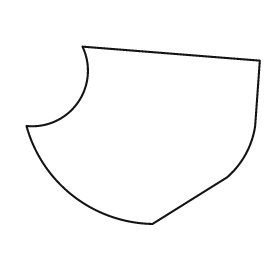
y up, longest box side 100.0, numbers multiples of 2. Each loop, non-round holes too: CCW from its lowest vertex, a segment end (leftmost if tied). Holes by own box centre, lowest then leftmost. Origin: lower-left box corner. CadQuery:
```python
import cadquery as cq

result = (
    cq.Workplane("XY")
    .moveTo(54.0, 0.0)
    .lineTo(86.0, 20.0)
    .threePointArc((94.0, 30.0), (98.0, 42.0))
    .lineTo(100.0, 70.0)
    .lineTo(24.0, 76.0)
    .threePointArc((22.0, 52.0), (0.0, 42.0))
    .threePointArc((20.0, 12.0), (54.0, 0.0))
    .close()
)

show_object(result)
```